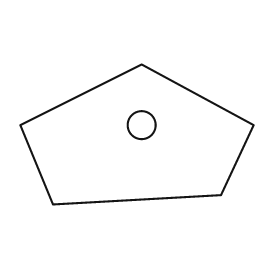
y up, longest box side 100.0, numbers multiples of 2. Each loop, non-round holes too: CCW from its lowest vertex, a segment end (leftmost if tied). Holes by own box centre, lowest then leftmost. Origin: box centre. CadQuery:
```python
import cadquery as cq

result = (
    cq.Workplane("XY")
    .moveTo(-36.0, -30.0)
    .lineTo(36.0, -26.0)
    .lineTo(50.0, 4.0)
    .lineTo(2.0, 30.0)
    .lineTo(-50.0, 4.0)
    .close()
    .moveTo(2.0, 4.0)
    .circle(6.0)
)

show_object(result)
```